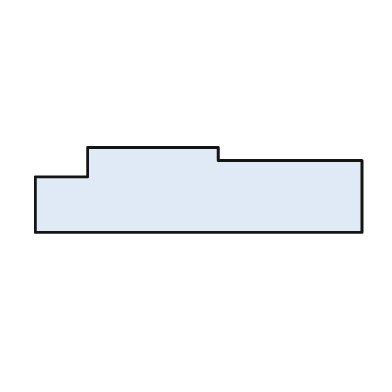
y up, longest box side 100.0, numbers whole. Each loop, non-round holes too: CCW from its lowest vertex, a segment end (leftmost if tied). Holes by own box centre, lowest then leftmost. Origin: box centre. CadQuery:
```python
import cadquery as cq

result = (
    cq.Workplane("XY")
    .moveTo(-50.0, -13.0)
    .lineTo(50.0, -13.0)
    .lineTo(50.0, 9.0)
    .lineTo(6.0, 9.0)
    .lineTo(6.0, 13.0)
    .lineTo(-34.0, 13.0)
    .lineTo(-34.0, 4.0)
    .lineTo(-50.0, 4.0)
    .close()
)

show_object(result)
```